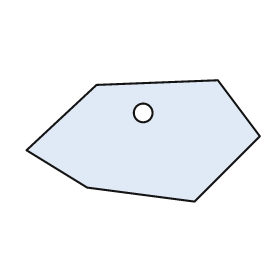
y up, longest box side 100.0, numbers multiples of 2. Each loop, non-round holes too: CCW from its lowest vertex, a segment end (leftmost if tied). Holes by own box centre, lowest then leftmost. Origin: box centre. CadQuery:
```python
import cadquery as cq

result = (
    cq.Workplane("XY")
    .moveTo(22.0, -26.0)
    .lineTo(50.0, 2.0)
    .lineTo(32.0, 26.0)
    .lineTo(-20.0, 24.0)
    .lineTo(-50.0, -4.0)
    .lineTo(-24.0, -20.0)
    .close()
    .moveTo(0.0, 12.0)
    .circle(4.0)
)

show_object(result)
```